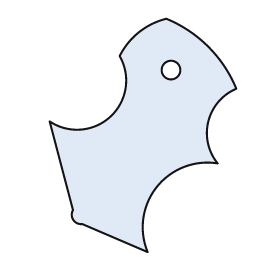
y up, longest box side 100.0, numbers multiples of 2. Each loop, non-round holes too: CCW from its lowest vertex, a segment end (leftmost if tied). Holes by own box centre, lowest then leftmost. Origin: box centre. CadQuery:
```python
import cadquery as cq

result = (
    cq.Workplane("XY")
    .moveTo(2.0, -50.0)
    .threePointArc((6.0, -22.0), (32.0, -12.0))
    .threePointArc((28.0, 6.0), (40.0, 20.0))
    .threePointArc((28.0, 38.0), (10.0, 50.0))
    .threePointArc((-2.0, 44.0), (-10.0, 34.0))
    .threePointArc((-14.0, 8.0), (-40.0, 6.0))
    .lineTo(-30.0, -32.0)
    .threePointArc((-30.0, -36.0), (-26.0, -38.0))
    .close()
    .moveTo(12.0, 28.0)
    .circle(4.0)
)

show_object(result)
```